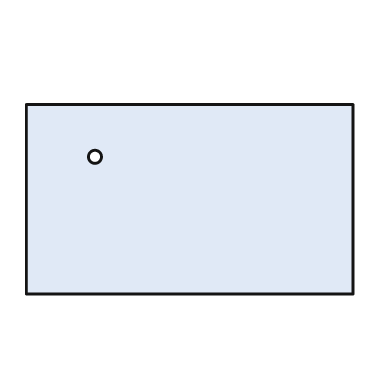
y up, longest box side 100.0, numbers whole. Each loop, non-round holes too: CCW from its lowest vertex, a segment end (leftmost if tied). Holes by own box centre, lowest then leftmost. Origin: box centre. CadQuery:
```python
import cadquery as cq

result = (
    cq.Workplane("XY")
    .moveTo(-50.0, -29.0)
    .lineTo(50.0, -29.0)
    .lineTo(50.0, 29.0)
    .lineTo(-50.0, 29.0)
    .close()
    .moveTo(-29.0, 13.0)
    .circle(2.0)
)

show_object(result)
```